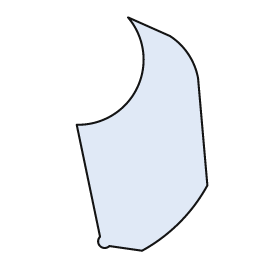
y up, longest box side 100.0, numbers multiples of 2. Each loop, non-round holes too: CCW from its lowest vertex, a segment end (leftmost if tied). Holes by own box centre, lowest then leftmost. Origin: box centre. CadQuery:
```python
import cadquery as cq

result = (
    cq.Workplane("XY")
    .moveTo(0.0, -50.0)
    .threePointArc((16.0, -38.0), (28.0, -22.0))
    .lineTo(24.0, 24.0)
    .threePointArc((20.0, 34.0), (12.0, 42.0))
    .lineTo(-6.0, 50.0)
    .threePointArc((-2.0, 20.0), (-28.0, 4.0))
    .lineTo(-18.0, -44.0)
    .threePointArc((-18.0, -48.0), (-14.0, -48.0))
    .close()
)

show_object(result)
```